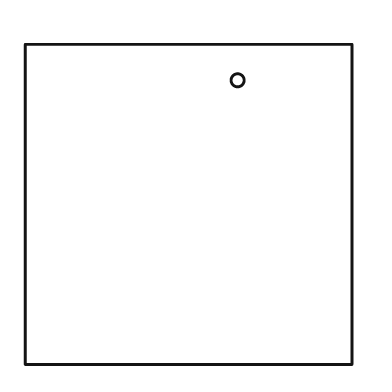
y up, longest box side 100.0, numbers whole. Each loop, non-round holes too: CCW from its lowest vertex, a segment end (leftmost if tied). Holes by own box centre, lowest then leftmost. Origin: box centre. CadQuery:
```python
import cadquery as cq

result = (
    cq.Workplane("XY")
    .moveTo(-50.0, -49.0)
    .lineTo(50.0, -49.0)
    .lineTo(50.0, 49.0)
    .lineTo(-50.0, 49.0)
    .close()
    .moveTo(15.0, 38.0)
    .circle(2.0)
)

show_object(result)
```